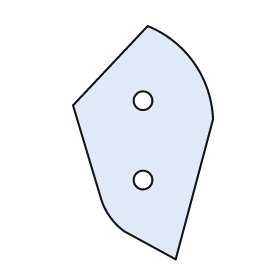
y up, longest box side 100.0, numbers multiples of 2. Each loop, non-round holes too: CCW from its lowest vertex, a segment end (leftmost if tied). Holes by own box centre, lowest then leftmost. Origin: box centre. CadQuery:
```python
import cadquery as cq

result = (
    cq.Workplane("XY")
    .moveTo(14.0, -50.0)
    .lineTo(30.0, 10.0)
    .threePointArc((22.0, 34.0), (2.0, 50.0))
    .lineTo(-30.0, 16.0)
    .lineTo(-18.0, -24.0)
    .threePointArc((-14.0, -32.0), (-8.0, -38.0))
    .close()
    .moveTo(0.0, -16.0)
    .circle(4.0)
    .moveTo(0.0, 18.0)
    .circle(4.0)
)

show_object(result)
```